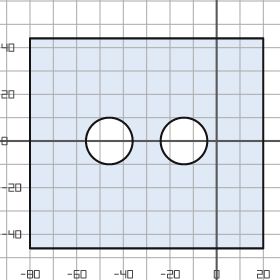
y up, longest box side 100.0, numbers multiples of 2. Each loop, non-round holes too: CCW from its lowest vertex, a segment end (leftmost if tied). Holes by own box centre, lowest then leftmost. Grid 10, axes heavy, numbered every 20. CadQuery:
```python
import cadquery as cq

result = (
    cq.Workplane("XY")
    .moveTo(-80.0, -46.0)
    .lineTo(20.0, -46.0)
    .lineTo(20.0, 44.0)
    .lineTo(-80.0, 44.0)
    .close()
    .moveTo(-46.0, 0.0)
    .circle(10.0)
    .moveTo(-14.0, 0.0)
    .circle(10.0)
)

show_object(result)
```